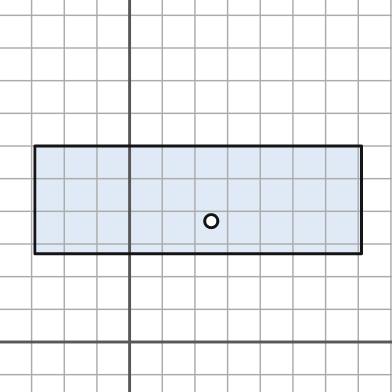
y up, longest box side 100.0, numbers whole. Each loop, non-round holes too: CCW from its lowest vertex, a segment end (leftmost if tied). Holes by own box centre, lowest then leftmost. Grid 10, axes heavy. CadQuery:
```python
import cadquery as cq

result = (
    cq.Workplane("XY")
    .moveTo(-29.0, 27.0)
    .lineTo(71.0, 27.0)
    .lineTo(71.0, 60.0)
    .lineTo(-29.0, 60.0)
    .close()
    .moveTo(25.0, 37.0)
    .circle(2.0)
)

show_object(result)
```